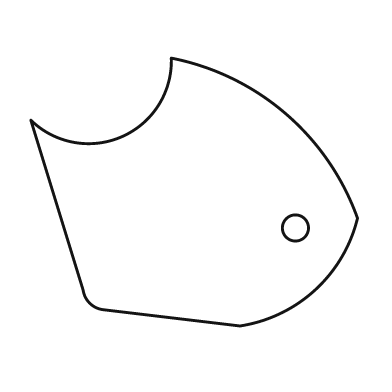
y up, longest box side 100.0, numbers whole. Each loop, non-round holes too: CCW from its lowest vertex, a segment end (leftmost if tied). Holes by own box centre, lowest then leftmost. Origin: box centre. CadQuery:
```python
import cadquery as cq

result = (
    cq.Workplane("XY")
    .moveTo(14.0, -41.0)
    .threePointArc((37.0, -30.0), (50.0, -8.0))
    .threePointArc((28.0, 24.0), (-7.0, 41.0))
    .threePointArc((-22.0, 17.0), (-50.0, 22.0))
    .lineTo(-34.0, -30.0)
    .threePointArc((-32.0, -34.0), (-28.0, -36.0))
    .close()
    .moveTo(31.0, -11.0)
    .circle(4.0)
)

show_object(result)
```